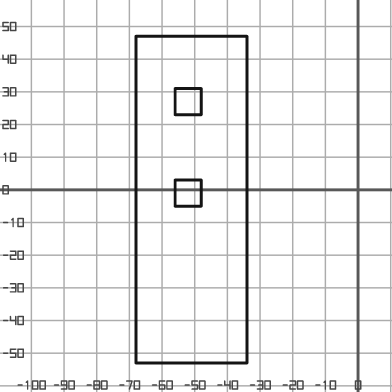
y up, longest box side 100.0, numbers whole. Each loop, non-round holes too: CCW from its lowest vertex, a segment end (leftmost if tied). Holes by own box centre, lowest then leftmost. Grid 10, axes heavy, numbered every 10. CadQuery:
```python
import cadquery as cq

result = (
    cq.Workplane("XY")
    .moveTo(-68.0, -53.0)
    .lineTo(-34.0, -53.0)
    .lineTo(-34.0, 47.0)
    .lineTo(-68.0, 47.0)
    .close()
    .moveTo(-56.0, -5.0)
    .lineTo(-48.0, -5.0)
    .lineTo(-48.0, 3.0)
    .lineTo(-56.0, 3.0)
    .close()
    .moveTo(-56.0, 23.0)
    .lineTo(-48.0, 23.0)
    .lineTo(-48.0, 31.0)
    .lineTo(-56.0, 31.0)
    .close()
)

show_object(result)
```